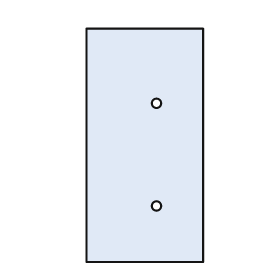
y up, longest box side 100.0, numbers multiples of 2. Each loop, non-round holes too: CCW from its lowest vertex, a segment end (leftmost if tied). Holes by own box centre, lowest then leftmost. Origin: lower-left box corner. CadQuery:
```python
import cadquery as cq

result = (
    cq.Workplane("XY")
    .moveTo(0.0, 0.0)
    .lineTo(50.0, 0.0)
    .lineTo(50.0, 100.0)
    .lineTo(0.0, 100.0)
    .close()
    .moveTo(30.0, 24.0)
    .circle(2.0)
    .moveTo(30.0, 68.0)
    .circle(2.0)
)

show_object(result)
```